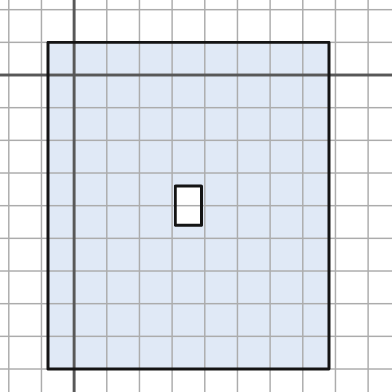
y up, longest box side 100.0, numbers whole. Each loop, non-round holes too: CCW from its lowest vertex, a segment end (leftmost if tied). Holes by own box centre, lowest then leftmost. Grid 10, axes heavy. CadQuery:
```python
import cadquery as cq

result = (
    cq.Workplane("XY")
    .moveTo(-8.0, -90.0)
    .lineTo(78.0, -90.0)
    .lineTo(78.0, 10.0)
    .lineTo(-8.0, 10.0)
    .close()
    .moveTo(31.0, -46.0)
    .lineTo(39.0, -46.0)
    .lineTo(39.0, -34.0)
    .lineTo(31.0, -34.0)
    .close()
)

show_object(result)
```